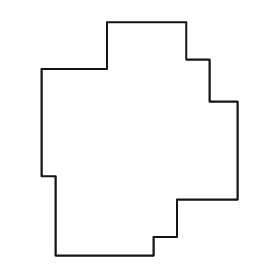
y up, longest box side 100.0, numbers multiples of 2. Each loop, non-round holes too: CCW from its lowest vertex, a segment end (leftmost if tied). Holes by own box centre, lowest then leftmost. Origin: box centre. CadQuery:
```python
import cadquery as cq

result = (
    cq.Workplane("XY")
    .moveTo(-36.0, -50.0)
    .lineTo(6.0, -50.0)
    .lineTo(6.0, -42.0)
    .lineTo(16.0, -42.0)
    .lineTo(16.0, -26.0)
    .lineTo(42.0, -26.0)
    .lineTo(42.0, 16.0)
    .lineTo(30.0, 16.0)
    .lineTo(30.0, 34.0)
    .lineTo(20.0, 34.0)
    .lineTo(20.0, 50.0)
    .lineTo(-14.0, 50.0)
    .lineTo(-14.0, 30.0)
    .lineTo(-42.0, 30.0)
    .lineTo(-42.0, -16.0)
    .lineTo(-36.0, -16.0)
    .close()
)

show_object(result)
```